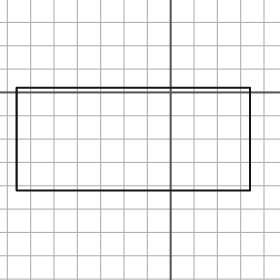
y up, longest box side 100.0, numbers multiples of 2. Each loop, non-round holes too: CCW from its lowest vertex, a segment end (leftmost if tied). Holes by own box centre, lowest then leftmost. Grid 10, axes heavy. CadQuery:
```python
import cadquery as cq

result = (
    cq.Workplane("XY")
    .moveTo(-66.0, -42.0)
    .lineTo(34.0, -42.0)
    .lineTo(34.0, 2.0)
    .lineTo(-66.0, 2.0)
    .close()
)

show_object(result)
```